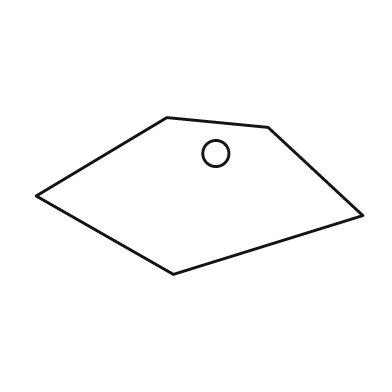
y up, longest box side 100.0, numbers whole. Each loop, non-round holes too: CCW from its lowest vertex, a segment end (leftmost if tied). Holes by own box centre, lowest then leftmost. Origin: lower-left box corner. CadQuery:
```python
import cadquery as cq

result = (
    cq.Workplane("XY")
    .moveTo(42.0, 0.0)
    .lineTo(100.0, 18.0)
    .lineTo(71.0, 45.0)
    .lineTo(40.0, 48.0)
    .lineTo(0.0, 24.0)
    .close()
    .moveTo(55.0, 37.0)
    .circle(4.0)
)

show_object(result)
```